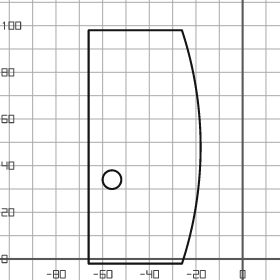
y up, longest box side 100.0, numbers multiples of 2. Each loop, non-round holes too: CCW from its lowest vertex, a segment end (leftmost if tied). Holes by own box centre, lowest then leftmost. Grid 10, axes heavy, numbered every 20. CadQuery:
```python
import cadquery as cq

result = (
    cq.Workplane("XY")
    .moveTo(-66.0, -2.0)
    .lineTo(-26.0, -2.0)
    .threePointArc((-18.0, 48.0), (-26.0, 98.0))
    .lineTo(-66.0, 98.0)
    .close()
    .moveTo(-56.0, 34.0)
    .circle(4.0)
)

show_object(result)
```